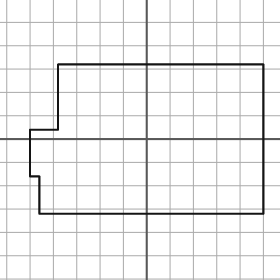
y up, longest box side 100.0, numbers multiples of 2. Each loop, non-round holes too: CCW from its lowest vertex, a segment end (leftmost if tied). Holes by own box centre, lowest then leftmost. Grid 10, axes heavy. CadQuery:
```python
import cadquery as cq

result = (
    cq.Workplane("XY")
    .moveTo(-46.0, -32.0)
    .lineTo(50.0, -32.0)
    .lineTo(50.0, 32.0)
    .lineTo(-38.0, 32.0)
    .lineTo(-38.0, 4.0)
    .lineTo(-50.0, 4.0)
    .lineTo(-50.0, -16.0)
    .lineTo(-46.0, -16.0)
    .close()
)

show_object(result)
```